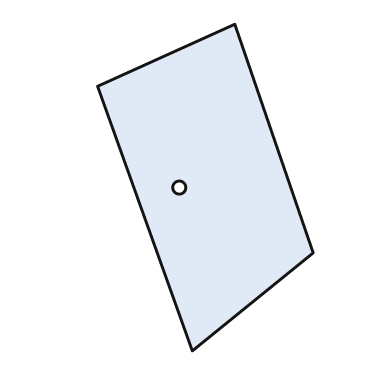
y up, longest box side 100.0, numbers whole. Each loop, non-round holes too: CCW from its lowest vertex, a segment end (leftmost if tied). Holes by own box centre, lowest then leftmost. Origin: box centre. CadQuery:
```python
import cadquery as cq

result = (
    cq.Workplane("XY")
    .moveTo(-4.0, -50.0)
    .lineTo(33.0, -20.0)
    .lineTo(9.0, 50.0)
    .lineTo(-33.0, 31.0)
    .close()
    .moveTo(-8.0, 0.0)
    .circle(2.0)
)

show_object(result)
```